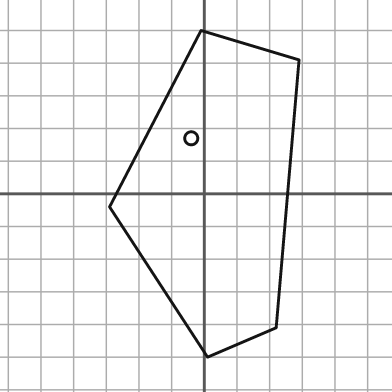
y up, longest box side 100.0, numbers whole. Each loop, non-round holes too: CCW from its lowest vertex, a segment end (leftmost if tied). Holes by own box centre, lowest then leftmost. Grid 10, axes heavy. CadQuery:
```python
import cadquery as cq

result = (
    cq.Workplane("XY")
    .moveTo(1.0, -50.0)
    .lineTo(22.0, -41.0)
    .lineTo(29.0, 41.0)
    .lineTo(-1.0, 50.0)
    .lineTo(-29.0, -4.0)
    .close()
    .moveTo(-4.0, 17.0)
    .circle(2.0)
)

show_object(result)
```